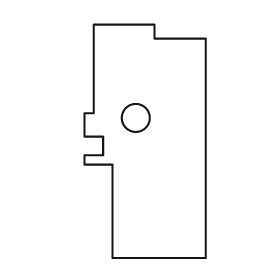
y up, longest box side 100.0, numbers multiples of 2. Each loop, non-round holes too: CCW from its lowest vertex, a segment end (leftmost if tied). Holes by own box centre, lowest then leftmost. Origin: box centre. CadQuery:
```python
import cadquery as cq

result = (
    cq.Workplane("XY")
    .moveTo(-14.0, -50.0)
    .lineTo(26.0, -50.0)
    .lineTo(26.0, 44.0)
    .lineTo(4.0, 44.0)
    .lineTo(4.0, 50.0)
    .lineTo(-22.0, 50.0)
    .lineTo(-22.0, 12.0)
    .lineTo(-26.0, 12.0)
    .lineTo(-26.0, 2.0)
    .lineTo(-18.0, 2.0)
    .lineTo(-18.0, -6.0)
    .lineTo(-26.0, -6.0)
    .lineTo(-26.0, -10.0)
    .lineTo(-14.0, -10.0)
    .close()
    .moveTo(-4.0, 10.0)
    .circle(6.0)
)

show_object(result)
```